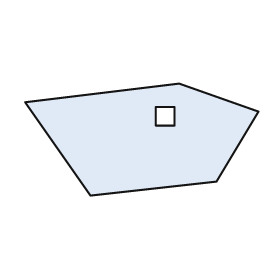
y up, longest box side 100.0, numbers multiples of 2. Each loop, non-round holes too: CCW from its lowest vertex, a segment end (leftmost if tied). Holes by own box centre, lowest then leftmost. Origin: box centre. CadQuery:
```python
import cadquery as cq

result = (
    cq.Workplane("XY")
    .moveTo(-22.0, -24.0)
    .lineTo(32.0, -18.0)
    .lineTo(50.0, 12.0)
    .lineTo(16.0, 24.0)
    .lineTo(-50.0, 16.0)
    .close()
    .moveTo(6.0, 6.0)
    .lineTo(14.0, 6.0)
    .lineTo(14.0, 14.0)
    .lineTo(6.0, 14.0)
    .close()
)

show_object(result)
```